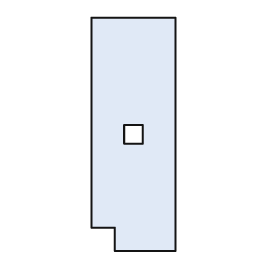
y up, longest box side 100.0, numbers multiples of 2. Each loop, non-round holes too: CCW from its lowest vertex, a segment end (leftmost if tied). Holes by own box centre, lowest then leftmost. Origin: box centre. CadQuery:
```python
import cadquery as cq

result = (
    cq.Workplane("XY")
    .moveTo(-8.0, -50.0)
    .lineTo(18.0, -50.0)
    .lineTo(18.0, 50.0)
    .lineTo(-18.0, 50.0)
    .lineTo(-18.0, -40.0)
    .lineTo(-8.0, -40.0)
    .close()
    .moveTo(-4.0, -4.0)
    .lineTo(4.0, -4.0)
    .lineTo(4.0, 4.0)
    .lineTo(-4.0, 4.0)
    .close()
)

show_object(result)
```